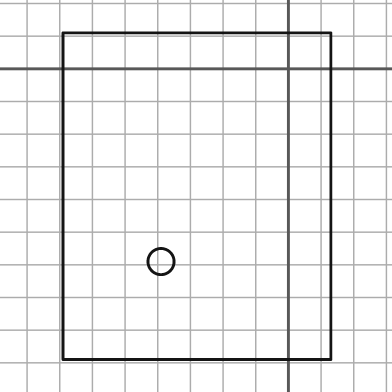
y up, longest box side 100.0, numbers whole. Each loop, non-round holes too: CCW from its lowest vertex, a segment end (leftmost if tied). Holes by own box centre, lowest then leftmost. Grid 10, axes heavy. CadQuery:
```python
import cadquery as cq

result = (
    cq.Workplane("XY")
    .moveTo(-69.0, -89.0)
    .lineTo(13.0, -89.0)
    .lineTo(13.0, 11.0)
    .lineTo(-69.0, 11.0)
    .close()
    .moveTo(-39.0, -59.0)
    .circle(4.0)
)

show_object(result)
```